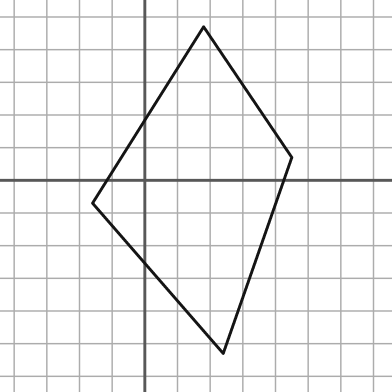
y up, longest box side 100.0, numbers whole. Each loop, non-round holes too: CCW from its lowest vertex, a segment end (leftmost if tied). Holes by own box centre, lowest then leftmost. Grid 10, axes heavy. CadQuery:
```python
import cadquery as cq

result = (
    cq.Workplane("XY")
    .moveTo(24.0, -53.0)
    .lineTo(45.0, 7.0)
    .lineTo(18.0, 47.0)
    .lineTo(-16.0, -7.0)
    .close()
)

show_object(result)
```